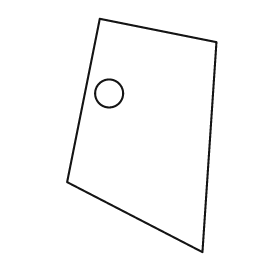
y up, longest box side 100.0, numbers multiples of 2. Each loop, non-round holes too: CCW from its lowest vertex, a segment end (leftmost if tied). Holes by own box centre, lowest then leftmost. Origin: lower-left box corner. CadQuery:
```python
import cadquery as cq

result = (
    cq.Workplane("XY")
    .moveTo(58.0, 0.0)
    .lineTo(64.0, 90.0)
    .lineTo(14.0, 100.0)
    .lineTo(0.0, 30.0)
    .close()
    .moveTo(18.0, 68.0)
    .circle(6.0)
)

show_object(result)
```